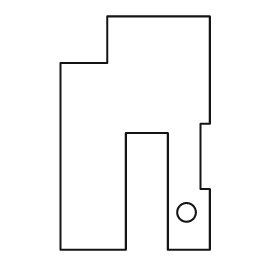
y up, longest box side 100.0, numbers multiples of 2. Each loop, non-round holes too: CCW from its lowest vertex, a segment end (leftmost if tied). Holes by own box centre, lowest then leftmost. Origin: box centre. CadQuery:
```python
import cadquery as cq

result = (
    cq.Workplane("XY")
    .moveTo(-32.0, -50.0)
    .lineTo(-4.0, -50.0)
    .lineTo(-4.0, 0.0)
    .lineTo(14.0, 0.0)
    .lineTo(14.0, -50.0)
    .lineTo(32.0, -50.0)
    .lineTo(32.0, -24.0)
    .lineTo(28.0, -24.0)
    .lineTo(28.0, 4.0)
    .lineTo(32.0, 4.0)
    .lineTo(32.0, 50.0)
    .lineTo(-12.0, 50.0)
    .lineTo(-12.0, 30.0)
    .lineTo(-32.0, 30.0)
    .close()
    .moveTo(22.0, -34.0)
    .circle(4.0)
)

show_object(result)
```